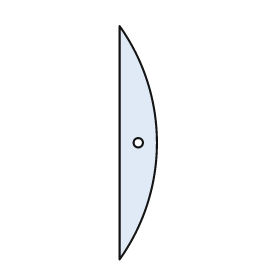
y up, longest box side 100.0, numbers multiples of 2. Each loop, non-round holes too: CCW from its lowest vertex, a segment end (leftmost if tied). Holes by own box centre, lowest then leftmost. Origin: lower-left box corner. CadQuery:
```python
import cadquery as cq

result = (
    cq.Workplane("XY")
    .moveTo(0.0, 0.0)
    .threePointArc((16.0, 50.0), (0.0, 100.0))
    .close()
    .moveTo(8.0, 50.0)
    .circle(2.0)
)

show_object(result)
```